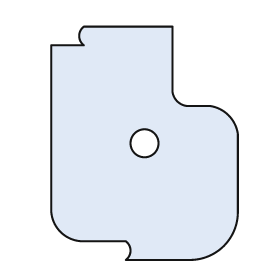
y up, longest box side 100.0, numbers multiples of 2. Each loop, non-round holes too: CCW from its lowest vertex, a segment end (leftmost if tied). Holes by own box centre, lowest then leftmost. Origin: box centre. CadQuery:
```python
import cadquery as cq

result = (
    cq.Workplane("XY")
    .moveTo(-8.0, -50.0)
    .lineTo(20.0, -50.0)
    .threePointArc((34.0, -44.0), (40.0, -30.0))
    .lineTo(40.0, 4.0)
    .threePointArc((36.0, 12.0), (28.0, 16.0))
    .lineTo(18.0, 16.0)
    .threePointArc((14.0, 18.0), (12.0, 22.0))
    .lineTo(12.0, 50.0)
    .lineTo(-26.0, 50.0)
    .threePointArc((-28.0, 46.0), (-26.0, 42.0))
    .lineTo(-40.0, 42.0)
    .lineTo(-40.0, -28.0)
    .threePointArc((-36.0, -38.0), (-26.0, -42.0))
    .lineTo(-8.0, -42.0)
    .threePointArc((-6.0, -46.0), (-8.0, -50.0))
    .close()
    .moveTo(0.0, 0.0)
    .circle(6.0)
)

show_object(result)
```